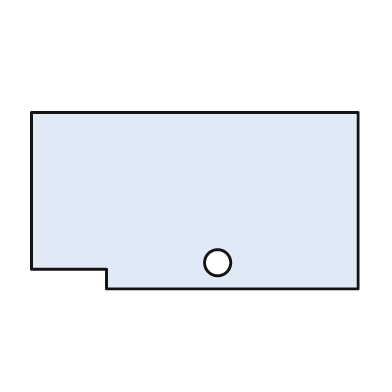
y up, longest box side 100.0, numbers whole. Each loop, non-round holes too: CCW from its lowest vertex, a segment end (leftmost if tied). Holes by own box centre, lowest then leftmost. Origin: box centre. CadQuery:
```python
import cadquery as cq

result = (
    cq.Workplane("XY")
    .moveTo(-27.0, -27.0)
    .lineTo(50.0, -27.0)
    .lineTo(50.0, 27.0)
    .lineTo(-50.0, 27.0)
    .lineTo(-50.0, -21.0)
    .lineTo(-27.0, -21.0)
    .close()
    .moveTo(7.0, -19.0)
    .circle(4.0)
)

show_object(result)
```